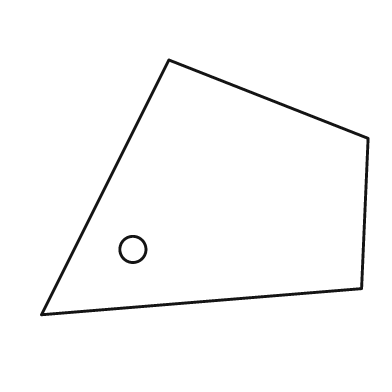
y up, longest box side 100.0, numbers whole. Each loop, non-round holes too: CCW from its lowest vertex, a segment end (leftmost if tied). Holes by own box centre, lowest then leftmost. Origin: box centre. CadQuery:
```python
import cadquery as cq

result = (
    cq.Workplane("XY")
    .moveTo(-50.0, -39.0)
    .lineTo(48.0, -31.0)
    .lineTo(50.0, 15.0)
    .lineTo(-11.0, 39.0)
    .close()
    .moveTo(-22.0, -19.0)
    .circle(4.0)
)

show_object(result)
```